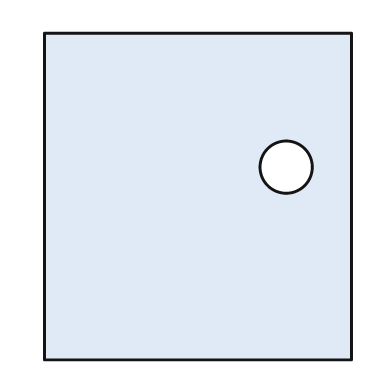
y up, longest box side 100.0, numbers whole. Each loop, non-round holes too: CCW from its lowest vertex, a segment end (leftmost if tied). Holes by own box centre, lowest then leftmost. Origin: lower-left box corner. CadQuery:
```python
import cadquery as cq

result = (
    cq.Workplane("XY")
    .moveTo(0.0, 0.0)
    .lineTo(94.0, 0.0)
    .lineTo(94.0, 100.0)
    .lineTo(0.0, 100.0)
    .close()
    .moveTo(74.0, 59.0)
    .circle(8.0)
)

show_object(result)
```